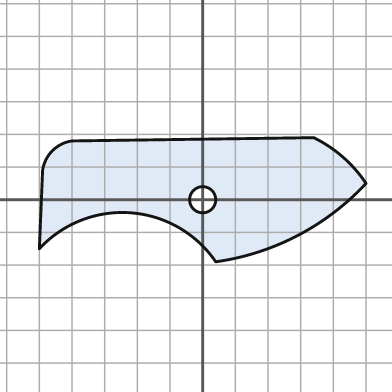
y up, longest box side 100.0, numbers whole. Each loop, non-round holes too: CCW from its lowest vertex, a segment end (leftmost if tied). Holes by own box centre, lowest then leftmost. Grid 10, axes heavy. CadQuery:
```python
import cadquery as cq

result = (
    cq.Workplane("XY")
    .moveTo(4.0, -19.0)
    .threePointArc((29.0, -11.0), (50.0, 5.0))
    .threePointArc((43.0, 13.0), (34.0, 19.0))
    .lineTo(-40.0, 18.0)
    .threePointArc((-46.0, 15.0), (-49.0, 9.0))
    .lineTo(-50.0, -15.0)
    .threePointArc((-22.0, -4.0), (4.0, -19.0))
    .close()
    .moveTo(0.0, 0.0)
    .circle(4.0)
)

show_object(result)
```